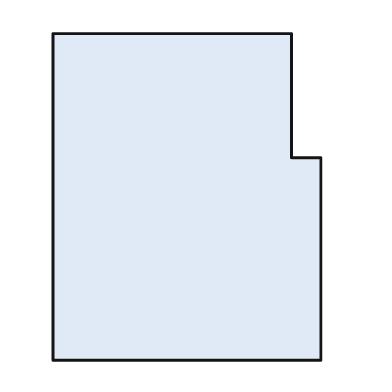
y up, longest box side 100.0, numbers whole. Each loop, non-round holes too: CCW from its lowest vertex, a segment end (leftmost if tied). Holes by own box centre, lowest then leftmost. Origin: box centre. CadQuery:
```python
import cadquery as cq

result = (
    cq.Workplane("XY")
    .moveTo(-41.0, -50.0)
    .lineTo(41.0, -50.0)
    .lineTo(41.0, 12.0)
    .lineTo(32.0, 12.0)
    .lineTo(32.0, 50.0)
    .lineTo(-41.0, 50.0)
    .close()
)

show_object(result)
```